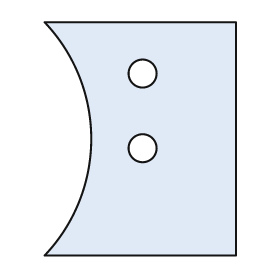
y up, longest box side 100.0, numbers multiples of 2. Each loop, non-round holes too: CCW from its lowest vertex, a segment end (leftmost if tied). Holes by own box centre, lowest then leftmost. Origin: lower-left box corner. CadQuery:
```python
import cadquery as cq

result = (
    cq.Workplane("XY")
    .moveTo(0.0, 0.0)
    .lineTo(82.0, 0.0)
    .lineTo(82.0, 100.0)
    .lineTo(0.0, 100.0)
    .threePointArc((20.0, 50.0), (0.0, 0.0))
    .close()
    .moveTo(42.0, 46.0)
    .circle(6.0)
    .moveTo(42.0, 78.0)
    .circle(6.0)
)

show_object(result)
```